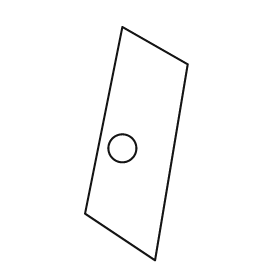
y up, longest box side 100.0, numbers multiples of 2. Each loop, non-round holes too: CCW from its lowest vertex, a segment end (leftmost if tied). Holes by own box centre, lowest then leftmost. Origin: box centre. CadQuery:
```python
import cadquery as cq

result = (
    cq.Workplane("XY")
    .moveTo(8.0, -50.0)
    .lineTo(22.0, 34.0)
    .lineTo(-6.0, 50.0)
    .lineTo(-22.0, -30.0)
    .close()
    .moveTo(-6.0, -2.0)
    .circle(6.0)
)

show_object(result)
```